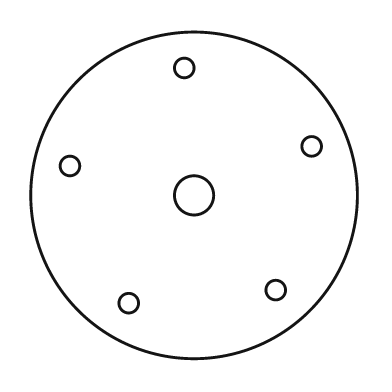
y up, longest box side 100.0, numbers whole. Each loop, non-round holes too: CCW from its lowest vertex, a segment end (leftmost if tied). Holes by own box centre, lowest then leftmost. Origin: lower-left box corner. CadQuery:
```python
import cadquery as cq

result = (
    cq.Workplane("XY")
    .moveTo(50.0, 50.0)
    .circle(50.0)
    .moveTo(30.0, 17.0)
    .circle(3.0)
    .moveTo(75.0, 21.0)
    .circle(3.0)
    .moveTo(50.0, 50.0)
    .circle(6.0)
    .moveTo(12.0, 59.0)
    .circle(3.0)
    .moveTo(86.0, 65.0)
    .circle(3.0)
    .moveTo(47.0, 89.0)
    .circle(3.0)
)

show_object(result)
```